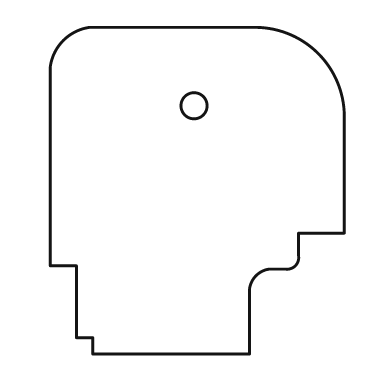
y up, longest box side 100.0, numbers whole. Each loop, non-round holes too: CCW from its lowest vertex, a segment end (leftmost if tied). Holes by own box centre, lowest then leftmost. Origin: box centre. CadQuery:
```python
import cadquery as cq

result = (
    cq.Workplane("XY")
    .moveTo(-32.0, -50.0)
    .lineTo(16.0, -50.0)
    .lineTo(16.0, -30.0)
    .threePointArc((18.0, -26.0), (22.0, -24.0))
    .lineTo(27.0, -24.0)
    .threePointArc((30.0, -23.0), (31.0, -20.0))
    .lineTo(31.0, -13.0)
    .lineTo(45.0, -13.0)
    .lineTo(45.0, 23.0)
    .threePointArc((37.0, 42.0), (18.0, 50.0))
    .lineTo(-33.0, 50.0)
    .threePointArc((-41.0, 46.0), (-45.0, 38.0))
    .lineTo(-45.0, -23.0)
    .lineTo(-37.0, -23.0)
    .lineTo(-37.0, -45.0)
    .lineTo(-32.0, -45.0)
    .close()
    .moveTo(-1.0, 26.0)
    .circle(4.0)
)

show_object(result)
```